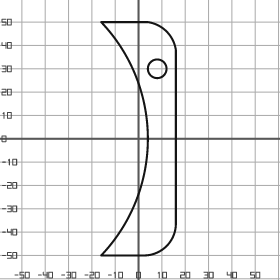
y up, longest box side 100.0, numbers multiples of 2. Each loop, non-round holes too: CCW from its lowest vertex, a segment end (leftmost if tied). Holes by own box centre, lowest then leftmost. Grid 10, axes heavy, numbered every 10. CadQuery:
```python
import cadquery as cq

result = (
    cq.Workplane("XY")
    .moveTo(-16.0, -50.0)
    .lineTo(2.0, -50.0)
    .threePointArc((12.0, -46.0), (16.0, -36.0))
    .lineTo(16.0, 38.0)
    .threePointArc((12.0, 46.0), (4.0, 50.0))
    .lineTo(-16.0, 50.0)
    .threePointArc((4.0, 0.0), (-16.0, -50.0))
    .close()
    .moveTo(8.0, 30.0)
    .circle(4.0)
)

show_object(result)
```